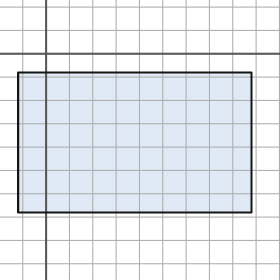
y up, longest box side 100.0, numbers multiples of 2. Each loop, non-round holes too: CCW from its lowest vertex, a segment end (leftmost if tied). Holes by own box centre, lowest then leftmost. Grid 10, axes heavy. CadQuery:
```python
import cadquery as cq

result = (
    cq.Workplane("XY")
    .moveTo(-12.0, -68.0)
    .lineTo(88.0, -68.0)
    .lineTo(88.0, -8.0)
    .lineTo(-12.0, -8.0)
    .close()
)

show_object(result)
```